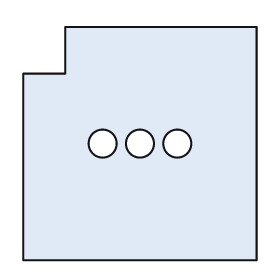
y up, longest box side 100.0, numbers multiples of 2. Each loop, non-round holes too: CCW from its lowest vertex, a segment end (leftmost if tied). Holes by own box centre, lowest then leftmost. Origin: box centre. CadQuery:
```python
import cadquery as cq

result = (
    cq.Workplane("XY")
    .moveTo(-50.0, -50.0)
    .lineTo(50.0, -50.0)
    .lineTo(50.0, 50.0)
    .lineTo(-32.0, 50.0)
    .lineTo(-32.0, 30.0)
    .lineTo(-50.0, 30.0)
    .close()
    .moveTo(-16.0, 0.0)
    .circle(6.0)
    .moveTo(0.0, 0.0)
    .circle(6.0)
    .moveTo(16.0, 0.0)
    .circle(6.0)
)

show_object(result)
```